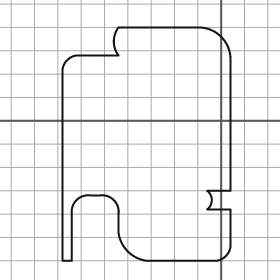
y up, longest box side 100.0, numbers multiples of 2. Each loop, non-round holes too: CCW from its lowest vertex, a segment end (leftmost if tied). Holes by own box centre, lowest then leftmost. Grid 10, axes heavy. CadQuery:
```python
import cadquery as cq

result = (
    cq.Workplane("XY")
    .moveTo(-68.0, -60.0)
    .lineTo(-64.0, -60.0)
    .lineTo(-64.0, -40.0)
    .threePointArc((-62.0, -34.0), (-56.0, -32.0))
    .lineTo(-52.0, -32.0)
    .threePointArc((-46.0, -34.0), (-44.0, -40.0))
    .lineTo(-44.0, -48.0)
    .threePointArc((-40.0, -56.0), (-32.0, -60.0))
    .lineTo(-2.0, -60.0)
    .threePointArc((2.0, -58.0), (4.0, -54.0))
    .lineTo(4.0, -38.0)
    .lineTo(-6.0, -38.0)
    .threePointArc((-4.0, -34.0), (-6.0, -30.0))
    .lineTo(4.0, -30.0)
    .lineTo(4.0, 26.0)
    .threePointArc((0.0, 36.0), (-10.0, 40.0))
    .lineTo(-44.0, 40.0)
    .threePointArc((-46.0, 34.0), (-44.0, 28.0))
    .lineTo(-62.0, 28.0)
    .threePointArc((-66.0, 26.0), (-68.0, 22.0))
    .close()
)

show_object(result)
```